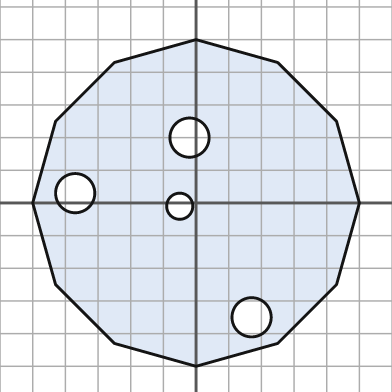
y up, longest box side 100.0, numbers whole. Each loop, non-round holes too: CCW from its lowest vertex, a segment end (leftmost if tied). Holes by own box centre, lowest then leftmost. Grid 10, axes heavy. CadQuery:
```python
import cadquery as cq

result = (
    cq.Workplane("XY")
    .moveTo(0.0, -50.0)
    .lineTo(25.0, -43.0)
    .lineTo(43.0, -25.0)
    .lineTo(50.0, 0.0)
    .lineTo(43.0, 25.0)
    .lineTo(25.0, 43.0)
    .lineTo(0.0, 50.0)
    .lineTo(-25.0, 43.0)
    .lineTo(-43.0, 25.0)
    .lineTo(-50.0, 0.0)
    .lineTo(-43.0, -25.0)
    .lineTo(-25.0, -43.0)
    .close()
    .moveTo(17.0, -35.0)
    .circle(6.0)
    .moveTo(-5.0, -1.0)
    .circle(4.0)
    .moveTo(-37.0, 3.0)
    .circle(6.0)
    .moveTo(-2.0, 20.0)
    .circle(6.0)
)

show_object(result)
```